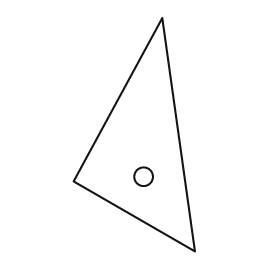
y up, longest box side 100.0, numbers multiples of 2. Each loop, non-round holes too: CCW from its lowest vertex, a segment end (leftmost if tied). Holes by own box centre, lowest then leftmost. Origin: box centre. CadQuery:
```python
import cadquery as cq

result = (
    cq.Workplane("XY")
    .moveTo(26.0, -50.0)
    .lineTo(12.0, 50.0)
    .lineTo(-26.0, -20.0)
    .close()
    .moveTo(4.0, -18.0)
    .circle(4.0)
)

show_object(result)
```